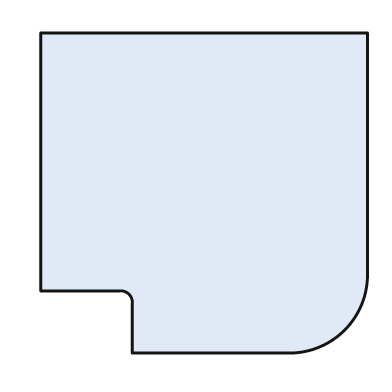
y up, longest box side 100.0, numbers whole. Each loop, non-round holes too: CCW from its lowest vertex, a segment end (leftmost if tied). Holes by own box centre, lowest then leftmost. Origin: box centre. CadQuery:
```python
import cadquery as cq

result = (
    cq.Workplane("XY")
    .moveTo(-22.0, -49.0)
    .lineTo(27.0, -49.0)
    .threePointArc((43.0, -42.0), (50.0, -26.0))
    .lineTo(50.0, 49.0)
    .lineTo(-50.0, 49.0)
    .lineTo(-50.0, -30.0)
    .lineTo(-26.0, -30.0)
    .threePointArc((-23.0, -31.0), (-22.0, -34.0))
    .close()
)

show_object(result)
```